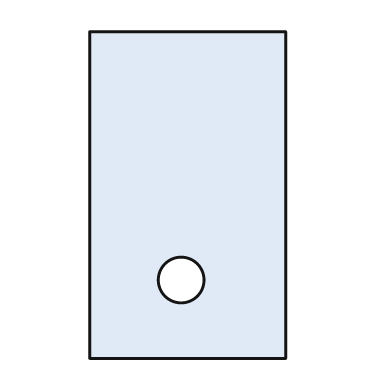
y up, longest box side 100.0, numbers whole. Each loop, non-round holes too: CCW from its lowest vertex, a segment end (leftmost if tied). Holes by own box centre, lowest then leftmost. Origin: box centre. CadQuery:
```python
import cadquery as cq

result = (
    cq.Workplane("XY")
    .moveTo(-30.0, -50.0)
    .lineTo(30.0, -50.0)
    .lineTo(30.0, 50.0)
    .lineTo(-30.0, 50.0)
    .close()
    .moveTo(-2.0, -26.0)
    .circle(7.0)
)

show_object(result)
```